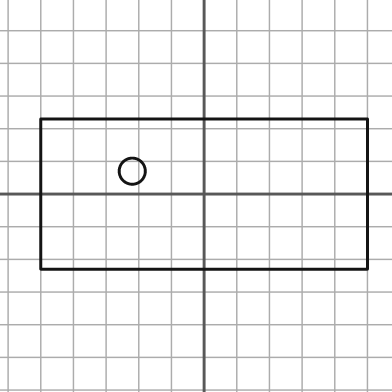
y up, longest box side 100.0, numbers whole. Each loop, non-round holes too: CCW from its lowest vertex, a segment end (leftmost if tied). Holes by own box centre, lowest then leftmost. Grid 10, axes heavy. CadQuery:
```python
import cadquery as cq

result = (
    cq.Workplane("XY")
    .moveTo(-50.0, -23.0)
    .lineTo(50.0, -23.0)
    .lineTo(50.0, 23.0)
    .lineTo(-50.0, 23.0)
    .close()
    .moveTo(-22.0, 7.0)
    .circle(4.0)
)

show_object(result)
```